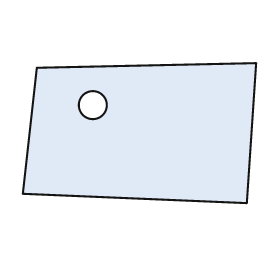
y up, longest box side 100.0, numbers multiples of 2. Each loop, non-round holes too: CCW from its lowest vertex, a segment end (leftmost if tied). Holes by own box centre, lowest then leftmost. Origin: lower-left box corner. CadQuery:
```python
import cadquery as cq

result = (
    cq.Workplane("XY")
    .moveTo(96.0, 0.0)
    .lineTo(100.0, 60.0)
    .lineTo(6.0, 58.0)
    .lineTo(0.0, 4.0)
    .close()
    .moveTo(30.0, 42.0)
    .circle(6.0)
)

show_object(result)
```